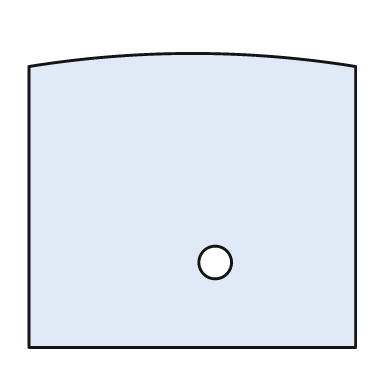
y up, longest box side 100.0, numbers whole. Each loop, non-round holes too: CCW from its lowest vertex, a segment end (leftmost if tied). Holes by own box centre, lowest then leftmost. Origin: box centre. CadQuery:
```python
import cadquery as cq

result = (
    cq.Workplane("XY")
    .moveTo(-50.0, -45.0)
    .lineTo(50.0, -45.0)
    .lineTo(50.0, 41.0)
    .threePointArc((0.0, 45.0), (-50.0, 41.0))
    .close()
    .moveTo(7.0, -19.0)
    .circle(5.0)
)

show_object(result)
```